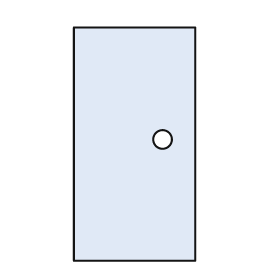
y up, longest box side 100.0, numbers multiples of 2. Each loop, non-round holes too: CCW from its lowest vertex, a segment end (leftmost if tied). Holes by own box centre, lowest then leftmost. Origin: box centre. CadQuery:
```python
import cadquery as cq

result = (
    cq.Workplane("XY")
    .moveTo(-26.0, -50.0)
    .lineTo(26.0, -50.0)
    .lineTo(26.0, 50.0)
    .lineTo(-26.0, 50.0)
    .close()
    .moveTo(12.0, 2.0)
    .circle(4.0)
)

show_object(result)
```